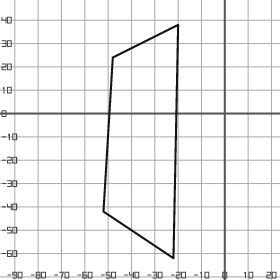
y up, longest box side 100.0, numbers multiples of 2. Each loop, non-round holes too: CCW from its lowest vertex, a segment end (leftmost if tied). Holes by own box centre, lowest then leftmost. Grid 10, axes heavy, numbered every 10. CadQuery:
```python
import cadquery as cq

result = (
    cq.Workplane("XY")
    .moveTo(-22.0, -62.0)
    .lineTo(-20.0, 38.0)
    .lineTo(-48.0, 24.0)
    .lineTo(-52.0, -42.0)
    .close()
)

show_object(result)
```